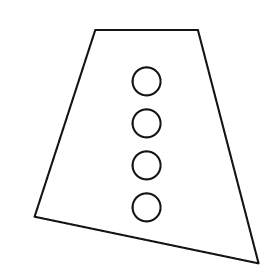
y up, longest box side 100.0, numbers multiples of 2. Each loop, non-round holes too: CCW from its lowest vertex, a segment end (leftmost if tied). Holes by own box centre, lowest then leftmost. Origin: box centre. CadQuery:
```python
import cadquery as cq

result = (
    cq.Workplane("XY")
    .moveTo(48.0, -50.0)
    .lineTo(22.0, 50.0)
    .lineTo(-22.0, 50.0)
    .lineTo(-48.0, -30.0)
    .close()
    .moveTo(0.0, -26.0)
    .circle(6.0)
    .moveTo(0.0, -8.0)
    .circle(6.0)
    .moveTo(0.0, 10.0)
    .circle(6.0)
    .moveTo(0.0, 28.0)
    .circle(6.0)
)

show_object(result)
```